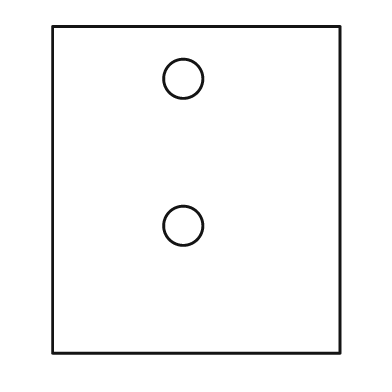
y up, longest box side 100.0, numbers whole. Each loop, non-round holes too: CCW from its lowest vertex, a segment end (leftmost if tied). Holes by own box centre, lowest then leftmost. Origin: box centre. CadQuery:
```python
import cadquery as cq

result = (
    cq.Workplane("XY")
    .moveTo(-44.0, -50.0)
    .lineTo(44.0, -50.0)
    .lineTo(44.0, 50.0)
    .lineTo(-44.0, 50.0)
    .close()
    .moveTo(-4.0, -11.0)
    .circle(6.0)
    .moveTo(-4.0, 34.0)
    .circle(6.0)
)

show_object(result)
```